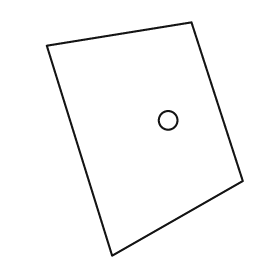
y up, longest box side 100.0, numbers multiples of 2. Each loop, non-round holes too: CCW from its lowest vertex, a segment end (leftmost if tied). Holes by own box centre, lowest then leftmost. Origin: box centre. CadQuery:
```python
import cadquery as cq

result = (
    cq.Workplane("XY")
    .moveTo(-14.0, -50.0)
    .lineTo(42.0, -18.0)
    .lineTo(20.0, 50.0)
    .lineTo(-42.0, 40.0)
    .close()
    .moveTo(10.0, 8.0)
    .circle(4.0)
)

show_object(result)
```